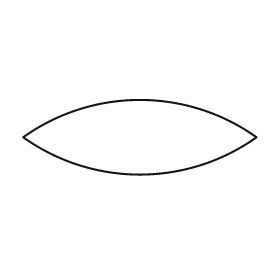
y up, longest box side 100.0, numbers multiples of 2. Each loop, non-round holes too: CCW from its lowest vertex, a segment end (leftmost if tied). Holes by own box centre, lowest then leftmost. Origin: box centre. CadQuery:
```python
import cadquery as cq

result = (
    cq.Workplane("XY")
    .moveTo(-50.0, 0.0)
    .threePointArc((0.0, -16.0), (50.0, 0.0))
    .threePointArc((0.0, 16.0), (-50.0, 0.0))
    .close()
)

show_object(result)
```